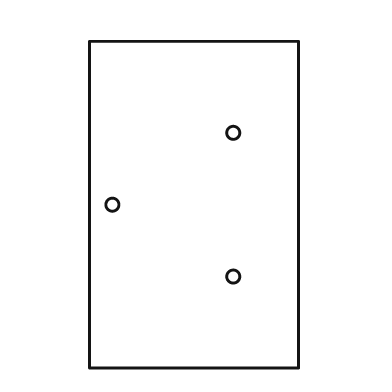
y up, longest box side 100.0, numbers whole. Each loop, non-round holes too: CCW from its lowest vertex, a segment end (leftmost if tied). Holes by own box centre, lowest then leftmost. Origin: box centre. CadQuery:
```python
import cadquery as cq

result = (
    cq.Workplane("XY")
    .moveTo(-32.0, -50.0)
    .lineTo(32.0, -50.0)
    .lineTo(32.0, 50.0)
    .lineTo(-32.0, 50.0)
    .close()
    .moveTo(12.0, -22.0)
    .circle(2.0)
    .moveTo(-25.0, 0.0)
    .circle(2.0)
    .moveTo(12.0, 22.0)
    .circle(2.0)
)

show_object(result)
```